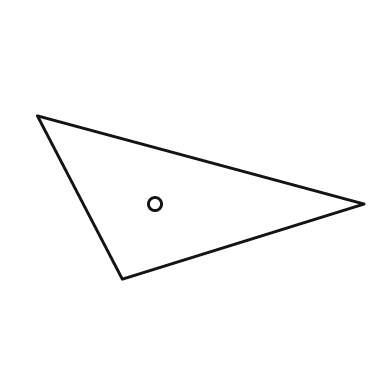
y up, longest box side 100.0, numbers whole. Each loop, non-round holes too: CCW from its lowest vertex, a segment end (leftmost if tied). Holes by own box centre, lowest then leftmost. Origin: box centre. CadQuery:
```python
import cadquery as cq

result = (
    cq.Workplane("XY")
    .moveTo(-24.0, -25.0)
    .lineTo(50.0, -2.0)
    .lineTo(-50.0, 25.0)
    .close()
    .moveTo(-14.0, -2.0)
    .circle(2.0)
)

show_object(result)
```